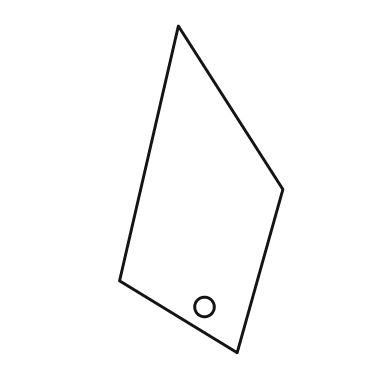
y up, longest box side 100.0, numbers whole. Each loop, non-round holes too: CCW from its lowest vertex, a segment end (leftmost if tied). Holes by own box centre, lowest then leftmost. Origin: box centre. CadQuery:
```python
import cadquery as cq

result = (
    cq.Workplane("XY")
    .moveTo(11.0, -50.0)
    .lineTo(25.0, 0.0)
    .lineTo(-7.0, 50.0)
    .lineTo(-25.0, -28.0)
    .close()
    .moveTo(1.0, -36.0)
    .circle(3.0)
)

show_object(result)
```